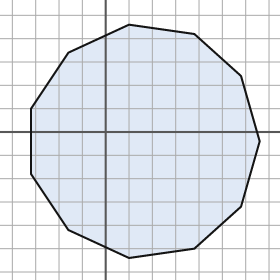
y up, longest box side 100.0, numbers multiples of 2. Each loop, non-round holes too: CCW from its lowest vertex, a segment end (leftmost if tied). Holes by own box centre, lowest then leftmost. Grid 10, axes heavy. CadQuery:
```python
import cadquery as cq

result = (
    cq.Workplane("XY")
    .moveTo(10.0, -54.0)
    .lineTo(38.0, -50.0)
    .lineTo(58.0, -32.0)
    .lineTo(66.0, -4.0)
    .lineTo(58.0, 24.0)
    .lineTo(38.0, 42.0)
    .lineTo(10.0, 46.0)
    .lineTo(-16.0, 34.0)
    .lineTo(-32.0, 10.0)
    .lineTo(-32.0, -18.0)
    .lineTo(-16.0, -42.0)
    .close()
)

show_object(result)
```